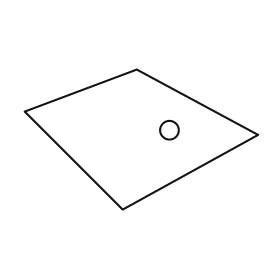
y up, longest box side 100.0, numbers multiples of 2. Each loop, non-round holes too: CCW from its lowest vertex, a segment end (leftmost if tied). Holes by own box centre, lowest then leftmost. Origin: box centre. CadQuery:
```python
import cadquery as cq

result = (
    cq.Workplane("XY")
    .moveTo(-8.0, -30.0)
    .lineTo(50.0, 2.0)
    .lineTo(-2.0, 30.0)
    .lineTo(-50.0, 12.0)
    .close()
    .moveTo(12.0, 4.0)
    .circle(4.0)
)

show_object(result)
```